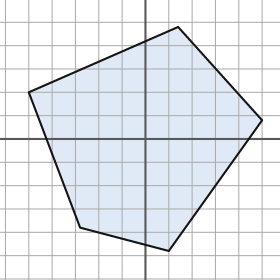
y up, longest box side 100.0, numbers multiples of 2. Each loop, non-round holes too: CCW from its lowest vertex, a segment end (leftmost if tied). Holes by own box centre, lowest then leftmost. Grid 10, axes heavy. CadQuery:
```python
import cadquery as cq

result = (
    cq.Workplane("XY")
    .moveTo(10.0, -48.0)
    .lineTo(50.0, 8.0)
    .lineTo(14.0, 48.0)
    .lineTo(-50.0, 20.0)
    .lineTo(-28.0, -38.0)
    .close()
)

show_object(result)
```